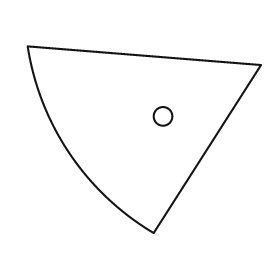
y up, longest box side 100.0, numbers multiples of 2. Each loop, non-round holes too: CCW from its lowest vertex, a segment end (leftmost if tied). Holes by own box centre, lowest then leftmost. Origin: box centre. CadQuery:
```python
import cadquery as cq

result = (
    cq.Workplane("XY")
    .moveTo(4.0, -40.0)
    .lineTo(50.0, 32.0)
    .lineTo(-50.0, 40.0)
    .threePointArc((-32.0, -6.0), (4.0, -40.0))
    .close()
    .moveTo(8.0, 10.0)
    .circle(4.0)
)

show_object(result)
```